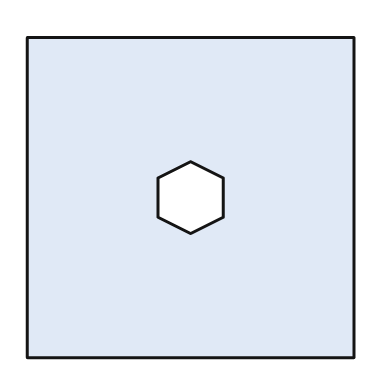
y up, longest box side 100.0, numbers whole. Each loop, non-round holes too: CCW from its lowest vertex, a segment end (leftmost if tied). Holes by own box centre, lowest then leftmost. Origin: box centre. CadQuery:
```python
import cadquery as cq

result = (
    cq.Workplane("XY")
    .moveTo(-50.0, -49.0)
    .lineTo(50.0, -49.0)
    .lineTo(50.0, 49.0)
    .lineTo(-50.0, 49.0)
    .close()
    .moveTo(0.0, -11.0)
    .lineTo(10.0, -6.0)
    .lineTo(10.0, 6.0)
    .lineTo(0.0, 11.0)
    .lineTo(-10.0, 6.0)
    .lineTo(-10.0, -6.0)
    .close()
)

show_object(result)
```